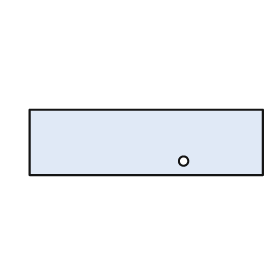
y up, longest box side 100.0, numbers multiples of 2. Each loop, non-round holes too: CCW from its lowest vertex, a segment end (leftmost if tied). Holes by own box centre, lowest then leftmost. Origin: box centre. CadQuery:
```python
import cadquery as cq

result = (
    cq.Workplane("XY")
    .moveTo(-50.0, -14.0)
    .lineTo(50.0, -14.0)
    .lineTo(50.0, 14.0)
    .lineTo(-50.0, 14.0)
    .close()
    .moveTo(16.0, -8.0)
    .circle(2.0)
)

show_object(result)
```